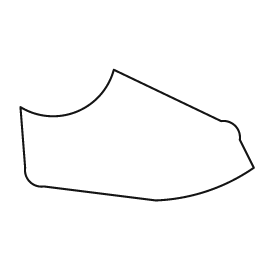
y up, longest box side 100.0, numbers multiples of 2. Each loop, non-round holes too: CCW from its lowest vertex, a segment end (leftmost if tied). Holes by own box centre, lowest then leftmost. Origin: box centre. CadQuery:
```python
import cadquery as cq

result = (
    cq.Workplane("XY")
    .moveTo(8.0, -28.0)
    .threePointArc((30.0, -24.0), (50.0, -14.0))
    .lineTo(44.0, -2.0)
    .threePointArc((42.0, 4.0), (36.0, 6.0))
    .lineTo(-10.0, 28.0)
    .threePointArc((-26.0, 10.0), (-50.0, 12.0))
    .lineTo(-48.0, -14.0)
    .threePointArc((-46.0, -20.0), (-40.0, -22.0))
    .close()
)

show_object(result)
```